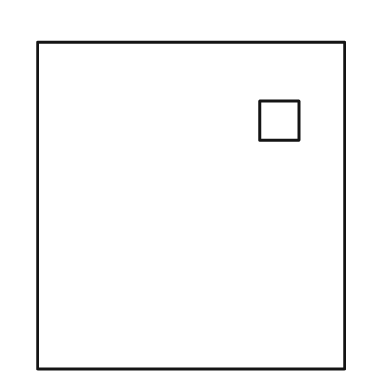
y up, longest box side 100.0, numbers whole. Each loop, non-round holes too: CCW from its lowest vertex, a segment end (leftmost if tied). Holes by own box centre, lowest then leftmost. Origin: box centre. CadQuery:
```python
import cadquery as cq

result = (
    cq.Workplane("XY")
    .moveTo(-47.0, -50.0)
    .lineTo(47.0, -50.0)
    .lineTo(47.0, 50.0)
    .lineTo(-47.0, 50.0)
    .close()
    .moveTo(21.0, 20.0)
    .lineTo(33.0, 20.0)
    .lineTo(33.0, 32.0)
    .lineTo(21.0, 32.0)
    .close()
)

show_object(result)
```